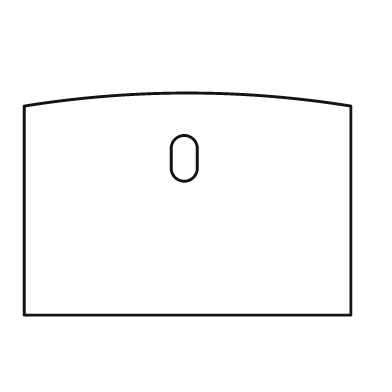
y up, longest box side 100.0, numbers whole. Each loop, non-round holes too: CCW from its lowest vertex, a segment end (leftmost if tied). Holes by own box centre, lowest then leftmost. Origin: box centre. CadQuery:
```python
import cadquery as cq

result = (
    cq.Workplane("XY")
    .moveTo(-50.0, -34.0)
    .lineTo(50.0, -34.0)
    .lineTo(50.0, 30.0)
    .threePointArc((0.0, 34.0), (-50.0, 30.0))
    .close()
    .moveTo(-5.0, 11.0)
    .threePointArc((-1.0, 7.0), (3.0, 11.0))
    .lineTo(3.0, 17.0)
    .threePointArc((-1.0, 21.0), (-5.0, 17.0))
    .close()
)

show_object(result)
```